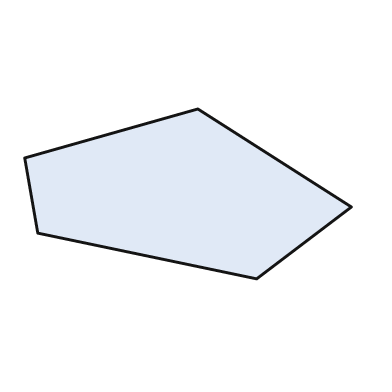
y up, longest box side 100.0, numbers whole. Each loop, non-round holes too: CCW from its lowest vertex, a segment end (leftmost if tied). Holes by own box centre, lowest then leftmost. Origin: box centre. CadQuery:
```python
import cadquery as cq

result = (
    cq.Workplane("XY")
    .moveTo(21.0, -26.0)
    .lineTo(50.0, -4.0)
    .lineTo(3.0, 26.0)
    .lineTo(-50.0, 11.0)
    .lineTo(-46.0, -12.0)
    .close()
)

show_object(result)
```